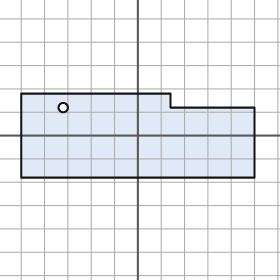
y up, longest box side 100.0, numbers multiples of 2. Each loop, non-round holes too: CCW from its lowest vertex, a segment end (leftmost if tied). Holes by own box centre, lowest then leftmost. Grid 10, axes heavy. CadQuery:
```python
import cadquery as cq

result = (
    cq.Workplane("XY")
    .moveTo(-50.0, -18.0)
    .lineTo(50.0, -18.0)
    .lineTo(50.0, 12.0)
    .lineTo(14.0, 12.0)
    .lineTo(14.0, 18.0)
    .lineTo(-50.0, 18.0)
    .close()
    .moveTo(-32.0, 12.0)
    .circle(2.0)
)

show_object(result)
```